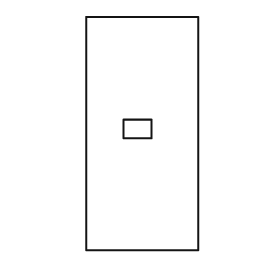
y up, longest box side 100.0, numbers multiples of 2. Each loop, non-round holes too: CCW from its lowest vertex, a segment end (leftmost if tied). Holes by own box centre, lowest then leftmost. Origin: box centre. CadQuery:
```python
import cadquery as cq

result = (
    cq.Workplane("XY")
    .moveTo(-24.0, -50.0)
    .lineTo(24.0, -50.0)
    .lineTo(24.0, 50.0)
    .lineTo(-24.0, 50.0)
    .close()
    .moveTo(-8.0, -2.0)
    .lineTo(4.0, -2.0)
    .lineTo(4.0, 6.0)
    .lineTo(-8.0, 6.0)
    .close()
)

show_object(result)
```